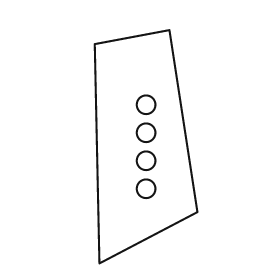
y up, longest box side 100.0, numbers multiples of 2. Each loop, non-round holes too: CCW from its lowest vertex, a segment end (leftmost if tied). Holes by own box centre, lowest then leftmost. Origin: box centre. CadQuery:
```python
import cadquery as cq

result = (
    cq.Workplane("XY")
    .moveTo(-20.0, -50.0)
    .lineTo(22.0, -28.0)
    .lineTo(10.0, 50.0)
    .lineTo(-22.0, 44.0)
    .close()
    .moveTo(0.0, -18.0)
    .circle(4.0)
    .moveTo(0.0, -6.0)
    .circle(4.0)
    .moveTo(0.0, 6.0)
    .circle(4.0)
    .moveTo(0.0, 18.0)
    .circle(4.0)
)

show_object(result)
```